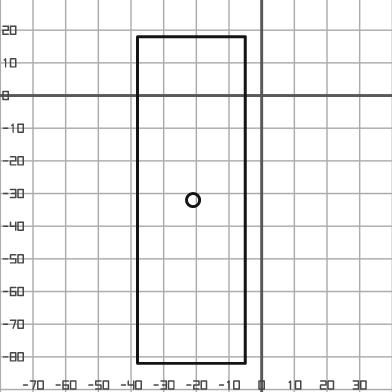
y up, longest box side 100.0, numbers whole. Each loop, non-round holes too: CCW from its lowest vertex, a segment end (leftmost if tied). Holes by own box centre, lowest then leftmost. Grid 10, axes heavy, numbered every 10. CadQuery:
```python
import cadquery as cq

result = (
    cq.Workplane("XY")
    .moveTo(-38.0, -82.0)
    .lineTo(-5.0, -82.0)
    .lineTo(-5.0, 18.0)
    .lineTo(-38.0, 18.0)
    .close()
    .moveTo(-21.0, -32.0)
    .circle(2.0)
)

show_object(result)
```